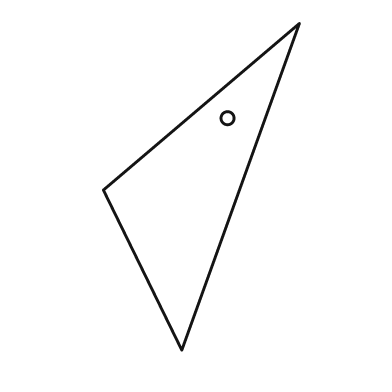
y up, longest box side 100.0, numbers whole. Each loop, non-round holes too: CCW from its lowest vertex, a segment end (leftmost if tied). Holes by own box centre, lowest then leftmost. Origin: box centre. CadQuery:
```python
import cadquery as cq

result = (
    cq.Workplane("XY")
    .moveTo(-6.0, -50.0)
    .lineTo(30.0, 50.0)
    .lineTo(-30.0, -1.0)
    .close()
    .moveTo(8.0, 21.0)
    .circle(2.0)
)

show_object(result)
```